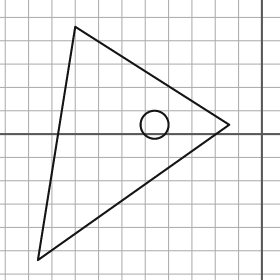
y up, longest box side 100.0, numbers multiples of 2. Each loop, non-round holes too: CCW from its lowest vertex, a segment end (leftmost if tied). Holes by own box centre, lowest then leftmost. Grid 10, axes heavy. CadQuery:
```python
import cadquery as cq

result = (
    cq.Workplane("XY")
    .moveTo(-96.0, -54.0)
    .lineTo(-14.0, 4.0)
    .lineTo(-80.0, 46.0)
    .close()
    .moveTo(-46.0, 4.0)
    .circle(6.0)
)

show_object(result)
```